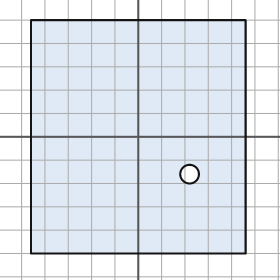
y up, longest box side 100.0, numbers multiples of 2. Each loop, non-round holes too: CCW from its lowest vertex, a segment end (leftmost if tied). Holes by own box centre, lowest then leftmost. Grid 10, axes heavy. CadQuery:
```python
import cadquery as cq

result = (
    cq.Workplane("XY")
    .moveTo(-46.0, -50.0)
    .lineTo(46.0, -50.0)
    .lineTo(46.0, 50.0)
    .lineTo(-46.0, 50.0)
    .close()
    .moveTo(22.0, -16.0)
    .circle(4.0)
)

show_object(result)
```